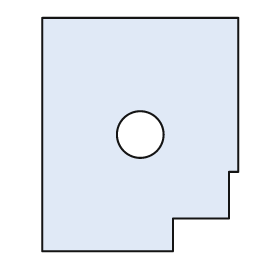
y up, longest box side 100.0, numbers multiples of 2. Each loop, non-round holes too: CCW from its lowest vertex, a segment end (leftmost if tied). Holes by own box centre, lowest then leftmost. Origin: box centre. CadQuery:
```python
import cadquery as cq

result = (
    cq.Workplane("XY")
    .moveTo(-42.0, -50.0)
    .lineTo(14.0, -50.0)
    .lineTo(14.0, -36.0)
    .lineTo(38.0, -36.0)
    .lineTo(38.0, -16.0)
    .lineTo(42.0, -16.0)
    .lineTo(42.0, 50.0)
    .lineTo(-42.0, 50.0)
    .close()
    .moveTo(0.0, 0.0)
    .circle(10.0)
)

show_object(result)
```